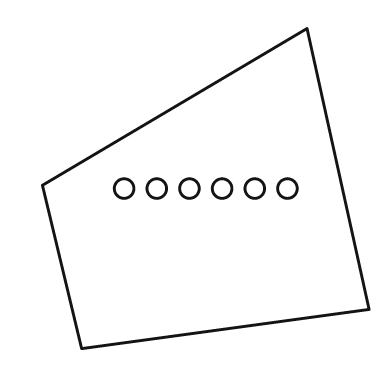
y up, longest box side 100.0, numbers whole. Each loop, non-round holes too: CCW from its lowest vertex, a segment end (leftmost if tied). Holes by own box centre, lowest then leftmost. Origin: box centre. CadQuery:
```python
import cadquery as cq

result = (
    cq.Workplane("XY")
    .moveTo(-38.0, -49.0)
    .lineTo(50.0, -37.0)
    .lineTo(31.0, 49.0)
    .lineTo(-50.0, 1.0)
    .close()
    .moveTo(-25.0, 0.0)
    .circle(3.0)
    .moveTo(-15.0, 0.0)
    .circle(3.0)
    .moveTo(-5.0, 0.0)
    .circle(3.0)
    .moveTo(5.0, 0.0)
    .circle(3.0)
    .moveTo(15.0, 0.0)
    .circle(3.0)
    .moveTo(25.0, 0.0)
    .circle(3.0)
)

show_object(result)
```